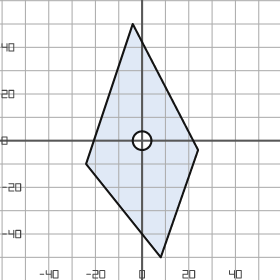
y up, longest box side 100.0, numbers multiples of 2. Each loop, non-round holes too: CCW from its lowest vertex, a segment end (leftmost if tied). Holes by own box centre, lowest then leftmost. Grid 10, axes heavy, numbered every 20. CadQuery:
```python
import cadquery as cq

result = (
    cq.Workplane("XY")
    .moveTo(8.0, -50.0)
    .lineTo(24.0, -4.0)
    .lineTo(-4.0, 50.0)
    .lineTo(-24.0, -10.0)
    .close()
    .moveTo(0.0, 0.0)
    .circle(4.0)
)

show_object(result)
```